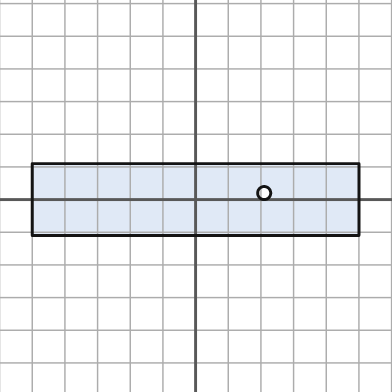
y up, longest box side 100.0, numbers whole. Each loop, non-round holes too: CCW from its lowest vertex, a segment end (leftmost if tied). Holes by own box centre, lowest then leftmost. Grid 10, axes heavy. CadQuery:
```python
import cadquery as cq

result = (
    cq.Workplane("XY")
    .moveTo(-50.0, -11.0)
    .lineTo(50.0, -11.0)
    .lineTo(50.0, 11.0)
    .lineTo(-50.0, 11.0)
    .close()
    .moveTo(21.0, 2.0)
    .circle(2.0)
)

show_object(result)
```